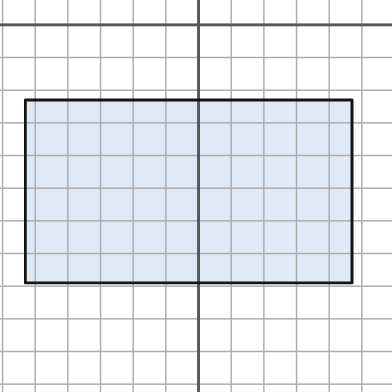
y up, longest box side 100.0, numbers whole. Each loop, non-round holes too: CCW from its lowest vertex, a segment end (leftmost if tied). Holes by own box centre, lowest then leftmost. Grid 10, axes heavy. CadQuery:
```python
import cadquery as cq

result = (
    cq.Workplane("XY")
    .moveTo(-53.0, -79.0)
    .lineTo(47.0, -79.0)
    .lineTo(47.0, -23.0)
    .lineTo(-53.0, -23.0)
    .close()
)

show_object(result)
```